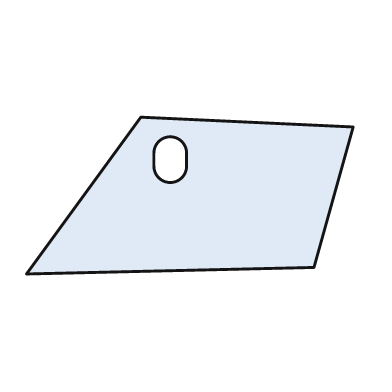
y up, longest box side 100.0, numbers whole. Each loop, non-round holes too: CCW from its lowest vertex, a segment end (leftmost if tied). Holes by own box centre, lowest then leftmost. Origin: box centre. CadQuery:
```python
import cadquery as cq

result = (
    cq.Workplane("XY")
    .moveTo(-50.0, -24.0)
    .lineTo(38.0, -22.0)
    .lineTo(50.0, 21.0)
    .lineTo(-15.0, 24.0)
    .close()
    .moveTo(-11.0, 9.0)
    .threePointArc((-6.0, 4.0), (-1.0, 9.0))
    .lineTo(-1.0, 13.0)
    .threePointArc((-6.0, 18.0), (-11.0, 13.0))
    .close()
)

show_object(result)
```